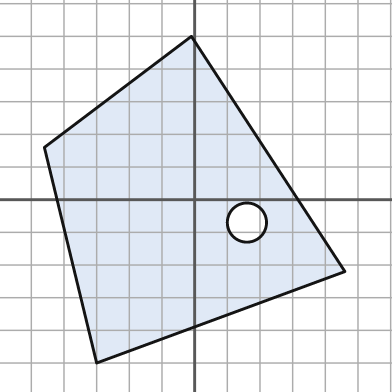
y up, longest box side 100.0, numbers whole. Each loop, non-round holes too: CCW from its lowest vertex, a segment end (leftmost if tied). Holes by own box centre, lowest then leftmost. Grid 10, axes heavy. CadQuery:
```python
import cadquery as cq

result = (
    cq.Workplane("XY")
    .moveTo(-30.0, -50.0)
    .lineTo(46.0, -22.0)
    .lineTo(-1.0, 50.0)
    .lineTo(-46.0, 16.0)
    .close()
    .moveTo(16.0, -7.0)
    .circle(6.0)
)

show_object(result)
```